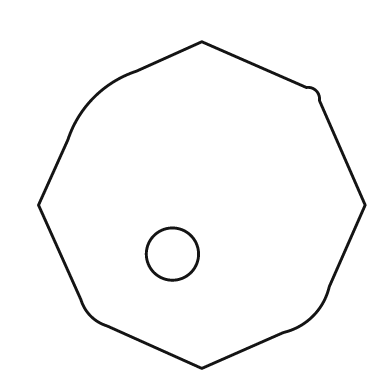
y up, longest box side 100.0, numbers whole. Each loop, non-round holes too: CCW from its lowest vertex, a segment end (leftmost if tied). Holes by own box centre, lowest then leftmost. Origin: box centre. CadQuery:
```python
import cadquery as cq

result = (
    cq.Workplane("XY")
    .moveTo(0.0, -50.0)
    .lineTo(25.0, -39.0)
    .threePointArc((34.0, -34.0), (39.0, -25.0))
    .lineTo(50.0, 0.0)
    .lineTo(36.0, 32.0)
    .threePointArc((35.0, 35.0), (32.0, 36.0))
    .lineTo(0.0, 50.0)
    .lineTo(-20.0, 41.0)
    .threePointArc((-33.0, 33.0), (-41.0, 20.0))
    .lineTo(-50.0, 0.0)
    .lineTo(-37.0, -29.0)
    .threePointArc((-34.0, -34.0), (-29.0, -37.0))
    .close()
    .moveTo(-9.0, -15.0)
    .circle(8.0)
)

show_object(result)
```